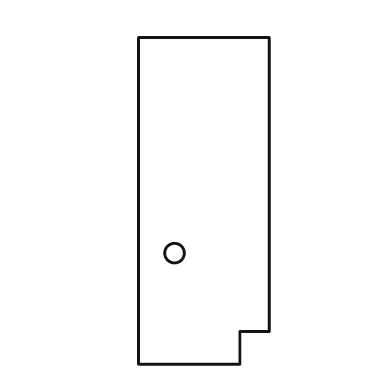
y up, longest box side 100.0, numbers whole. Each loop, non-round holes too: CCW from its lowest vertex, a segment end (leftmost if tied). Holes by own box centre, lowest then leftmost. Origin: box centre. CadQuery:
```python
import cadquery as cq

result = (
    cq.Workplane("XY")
    .moveTo(-20.0, -50.0)
    .lineTo(11.0, -50.0)
    .lineTo(11.0, -40.0)
    .lineTo(20.0, -40.0)
    .lineTo(20.0, 50.0)
    .lineTo(-20.0, 50.0)
    .close()
    .moveTo(-9.0, -16.0)
    .circle(3.0)
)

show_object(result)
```